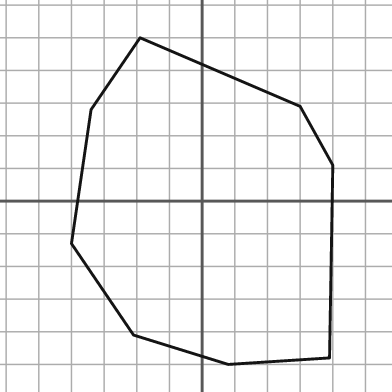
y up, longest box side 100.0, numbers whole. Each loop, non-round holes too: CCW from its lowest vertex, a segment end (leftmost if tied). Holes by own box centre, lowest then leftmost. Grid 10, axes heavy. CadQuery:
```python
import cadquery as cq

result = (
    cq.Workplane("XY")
    .moveTo(8.0, -50.0)
    .lineTo(39.0, -48.0)
    .lineTo(40.0, 11.0)
    .lineTo(30.0, 29.0)
    .lineTo(-19.0, 50.0)
    .lineTo(-34.0, 28.0)
    .lineTo(-40.0, -13.0)
    .lineTo(-21.0, -41.0)
    .close()
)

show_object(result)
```